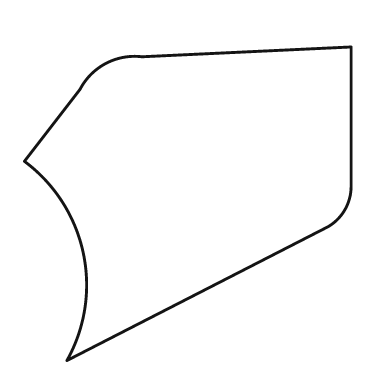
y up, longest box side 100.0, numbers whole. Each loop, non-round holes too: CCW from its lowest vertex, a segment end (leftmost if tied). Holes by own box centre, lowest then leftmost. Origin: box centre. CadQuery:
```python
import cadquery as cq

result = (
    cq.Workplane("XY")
    .moveTo(-37.0, -48.0)
    .lineTo(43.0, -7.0)
    .threePointArc((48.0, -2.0), (50.0, 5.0))
    .lineTo(50.0, 48.0)
    .lineTo(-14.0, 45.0)
    .threePointArc((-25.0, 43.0), (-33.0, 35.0))
    .lineTo(-50.0, 13.0)
    .threePointArc((-32.0, -15.0), (-37.0, -48.0))
    .close()
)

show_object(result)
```